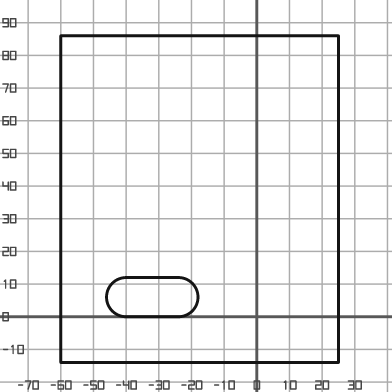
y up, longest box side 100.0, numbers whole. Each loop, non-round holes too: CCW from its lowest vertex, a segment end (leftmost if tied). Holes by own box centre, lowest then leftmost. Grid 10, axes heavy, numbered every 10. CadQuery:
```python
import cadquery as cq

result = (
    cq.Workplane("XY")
    .moveTo(-60.0, -14.0)
    .lineTo(25.0, -14.0)
    .lineTo(25.0, 86.0)
    .lineTo(-60.0, 86.0)
    .close()
    .moveTo(-40.0, 0.0)
    .lineTo(-24.0, 0.0)
    .threePointArc((-18.0, 6.0), (-24.0, 12.0))
    .lineTo(-40.0, 12.0)
    .threePointArc((-46.0, 6.0), (-40.0, 0.0))
    .close()
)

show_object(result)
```